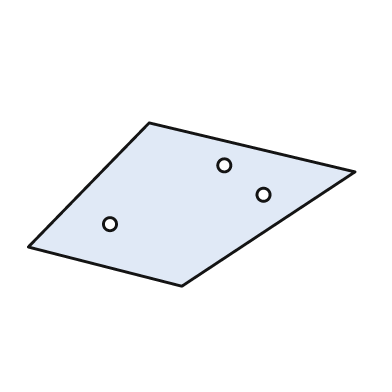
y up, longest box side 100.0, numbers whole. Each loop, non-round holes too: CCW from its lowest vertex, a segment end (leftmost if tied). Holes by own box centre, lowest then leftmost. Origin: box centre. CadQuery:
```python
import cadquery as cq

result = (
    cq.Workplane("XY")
    .moveTo(-3.0, -25.0)
    .lineTo(50.0, 10.0)
    .lineTo(-13.0, 25.0)
    .lineTo(-50.0, -13.0)
    .close()
    .moveTo(-25.0, -6.0)
    .circle(2.0)
    .moveTo(22.0, 3.0)
    .circle(2.0)
    .moveTo(10.0, 12.0)
    .circle(2.0)
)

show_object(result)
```